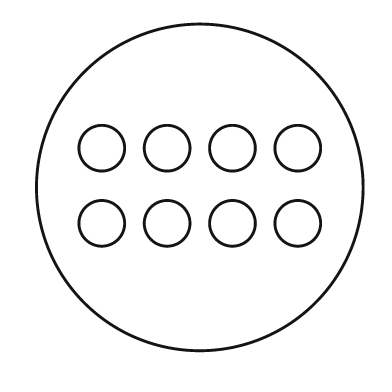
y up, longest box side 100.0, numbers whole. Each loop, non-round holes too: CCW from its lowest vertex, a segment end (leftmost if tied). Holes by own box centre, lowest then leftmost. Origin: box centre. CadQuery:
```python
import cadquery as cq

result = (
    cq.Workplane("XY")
    .moveTo(0.0, 0.0)
    .circle(50.0)
    .moveTo(-30.0, -11.0)
    .circle(7.0)
    .moveTo(-10.0, -11.0)
    .circle(7.0)
    .moveTo(10.0, -11.0)
    .circle(7.0)
    .moveTo(30.0, -11.0)
    .circle(7.0)
    .moveTo(-30.0, 12.0)
    .circle(7.0)
    .moveTo(-10.0, 12.0)
    .circle(7.0)
    .moveTo(10.0, 12.0)
    .circle(7.0)
    .moveTo(30.0, 12.0)
    .circle(7.0)
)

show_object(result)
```